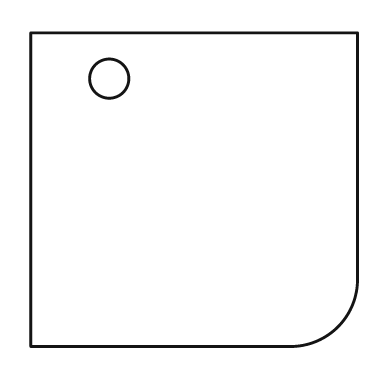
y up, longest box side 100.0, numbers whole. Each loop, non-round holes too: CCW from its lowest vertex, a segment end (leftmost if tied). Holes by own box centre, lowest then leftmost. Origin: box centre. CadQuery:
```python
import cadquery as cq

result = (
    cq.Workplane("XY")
    .moveTo(-50.0, -48.0)
    .lineTo(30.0, -48.0)
    .threePointArc((44.0, -42.0), (50.0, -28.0))
    .lineTo(50.0, 48.0)
    .lineTo(-50.0, 48.0)
    .close()
    .moveTo(-26.0, 34.0)
    .circle(6.0)
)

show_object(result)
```